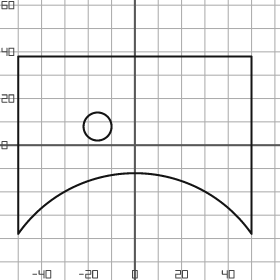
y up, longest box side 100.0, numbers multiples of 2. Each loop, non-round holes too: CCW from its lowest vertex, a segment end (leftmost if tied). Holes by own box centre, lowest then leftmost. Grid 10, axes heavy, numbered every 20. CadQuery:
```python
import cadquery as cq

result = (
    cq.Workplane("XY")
    .moveTo(-50.0, -38.0)
    .threePointArc((0.0, -12.0), (50.0, -38.0))
    .lineTo(50.0, 38.0)
    .lineTo(-50.0, 38.0)
    .close()
    .moveTo(-16.0, 8.0)
    .circle(6.0)
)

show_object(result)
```